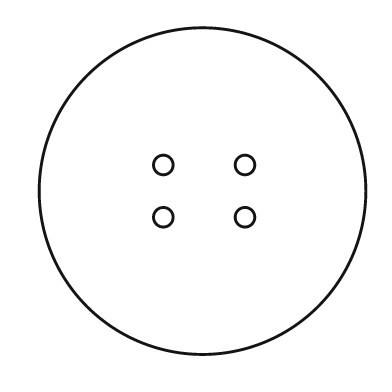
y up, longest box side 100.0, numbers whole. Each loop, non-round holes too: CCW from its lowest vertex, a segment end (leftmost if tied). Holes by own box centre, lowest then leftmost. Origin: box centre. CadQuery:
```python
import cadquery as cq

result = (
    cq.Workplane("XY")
    .moveTo(0.0, 0.0)
    .circle(50.0)
    .moveTo(-12.0, -8.0)
    .circle(3.0)
    .moveTo(13.0, -8.0)
    .circle(3.0)
    .moveTo(-12.0, 8.0)
    .circle(3.0)
    .moveTo(13.0, 8.0)
    .circle(3.0)
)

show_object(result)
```